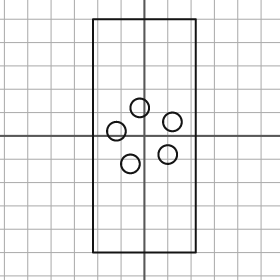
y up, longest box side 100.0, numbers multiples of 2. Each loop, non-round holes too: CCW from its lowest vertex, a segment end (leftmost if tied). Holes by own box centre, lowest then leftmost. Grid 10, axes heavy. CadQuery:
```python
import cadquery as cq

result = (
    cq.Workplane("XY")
    .moveTo(-22.0, -50.0)
    .lineTo(22.0, -50.0)
    .lineTo(22.0, 50.0)
    .lineTo(-22.0, 50.0)
    .close()
    .moveTo(-6.0, -12.0)
    .circle(4.0)
    .moveTo(10.0, -8.0)
    .circle(4.0)
    .moveTo(-12.0, 2.0)
    .circle(4.0)
    .moveTo(12.0, 6.0)
    .circle(4.0)
    .moveTo(-2.0, 12.0)
    .circle(4.0)
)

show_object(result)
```